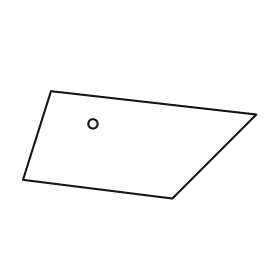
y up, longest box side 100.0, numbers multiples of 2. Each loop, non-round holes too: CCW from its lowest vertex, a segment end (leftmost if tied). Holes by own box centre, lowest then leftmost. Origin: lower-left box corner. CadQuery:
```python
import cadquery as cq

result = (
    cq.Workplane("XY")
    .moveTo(64.0, 0.0)
    .lineTo(100.0, 36.0)
    .lineTo(12.0, 46.0)
    .lineTo(0.0, 8.0)
    .close()
    .moveTo(30.0, 32.0)
    .circle(2.0)
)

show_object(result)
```